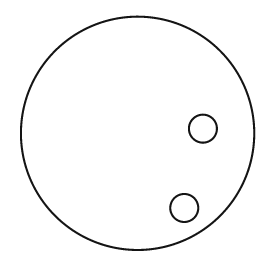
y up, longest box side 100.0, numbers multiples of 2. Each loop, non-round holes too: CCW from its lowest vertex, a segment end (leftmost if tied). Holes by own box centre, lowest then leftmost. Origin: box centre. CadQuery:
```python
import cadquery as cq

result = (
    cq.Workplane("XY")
    .moveTo(0.0, 0.0)
    .circle(50.0)
    .moveTo(20.0, -32.0)
    .circle(6.0)
    .moveTo(28.0, 2.0)
    .circle(6.0)
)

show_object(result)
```